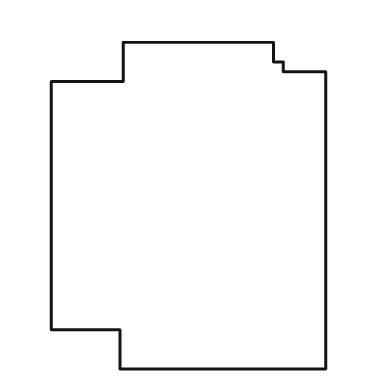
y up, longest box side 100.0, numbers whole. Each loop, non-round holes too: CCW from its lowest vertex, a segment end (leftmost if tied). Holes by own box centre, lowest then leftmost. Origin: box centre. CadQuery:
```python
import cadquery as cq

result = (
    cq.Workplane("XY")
    .moveTo(-21.0, -50.0)
    .lineTo(42.0, -50.0)
    .lineTo(42.0, 41.0)
    .lineTo(29.0, 41.0)
    .lineTo(29.0, 44.0)
    .lineTo(26.0, 44.0)
    .lineTo(26.0, 50.0)
    .lineTo(-20.0, 50.0)
    .lineTo(-20.0, 38.0)
    .lineTo(-42.0, 38.0)
    .lineTo(-42.0, -38.0)
    .lineTo(-21.0, -38.0)
    .close()
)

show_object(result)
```